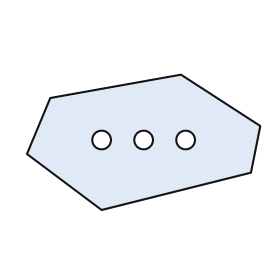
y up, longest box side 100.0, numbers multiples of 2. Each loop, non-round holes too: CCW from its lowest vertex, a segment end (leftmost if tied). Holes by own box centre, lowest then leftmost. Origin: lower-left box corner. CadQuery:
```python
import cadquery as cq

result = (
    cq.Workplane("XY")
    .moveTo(32.0, 0.0)
    .lineTo(96.0, 16.0)
    .lineTo(100.0, 36.0)
    .lineTo(66.0, 58.0)
    .lineTo(10.0, 48.0)
    .lineTo(0.0, 24.0)
    .close()
    .moveTo(32.0, 30.0)
    .circle(4.0)
    .moveTo(50.0, 30.0)
    .circle(4.0)
    .moveTo(68.0, 30.0)
    .circle(4.0)
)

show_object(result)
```